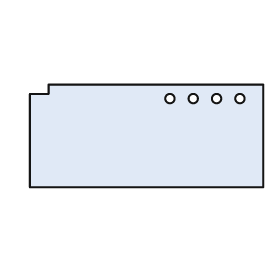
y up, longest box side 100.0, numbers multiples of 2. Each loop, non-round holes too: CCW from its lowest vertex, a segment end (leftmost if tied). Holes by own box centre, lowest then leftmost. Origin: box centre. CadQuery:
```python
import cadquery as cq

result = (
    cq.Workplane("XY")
    .moveTo(-50.0, -22.0)
    .lineTo(50.0, -22.0)
    .lineTo(50.0, 22.0)
    .lineTo(-42.0, 22.0)
    .lineTo(-42.0, 18.0)
    .lineTo(-50.0, 18.0)
    .close()
    .moveTo(10.0, 16.0)
    .circle(2.0)
    .moveTo(20.0, 16.0)
    .circle(2.0)
    .moveTo(30.0, 16.0)
    .circle(2.0)
    .moveTo(40.0, 16.0)
    .circle(2.0)
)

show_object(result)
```